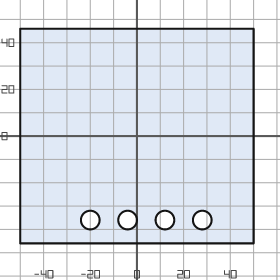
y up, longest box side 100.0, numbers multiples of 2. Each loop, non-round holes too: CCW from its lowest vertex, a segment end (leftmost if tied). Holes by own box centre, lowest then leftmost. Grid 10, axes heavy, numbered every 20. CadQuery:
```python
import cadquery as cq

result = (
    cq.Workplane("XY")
    .moveTo(-50.0, -46.0)
    .lineTo(50.0, -46.0)
    .lineTo(50.0, 46.0)
    .lineTo(-50.0, 46.0)
    .close()
    .moveTo(-20.0, -36.0)
    .circle(4.0)
    .moveTo(-4.0, -36.0)
    .circle(4.0)
    .moveTo(12.0, -36.0)
    .circle(4.0)
    .moveTo(28.0, -36.0)
    .circle(4.0)
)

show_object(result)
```